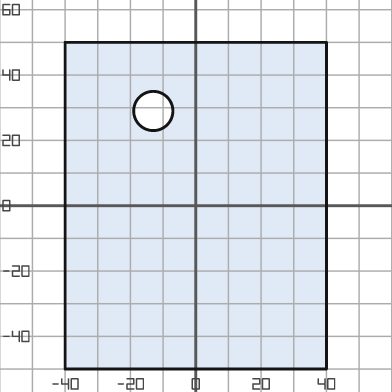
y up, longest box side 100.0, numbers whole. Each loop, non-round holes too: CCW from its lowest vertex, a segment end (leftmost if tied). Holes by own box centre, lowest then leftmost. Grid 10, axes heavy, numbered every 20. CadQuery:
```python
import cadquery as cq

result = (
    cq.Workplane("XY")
    .moveTo(-40.0, -50.0)
    .lineTo(40.0, -50.0)
    .lineTo(40.0, 50.0)
    .lineTo(-40.0, 50.0)
    .close()
    .moveTo(-13.0, 29.0)
    .circle(6.0)
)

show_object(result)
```